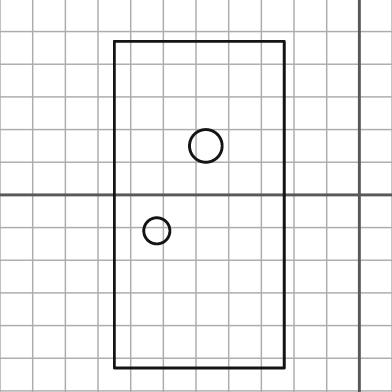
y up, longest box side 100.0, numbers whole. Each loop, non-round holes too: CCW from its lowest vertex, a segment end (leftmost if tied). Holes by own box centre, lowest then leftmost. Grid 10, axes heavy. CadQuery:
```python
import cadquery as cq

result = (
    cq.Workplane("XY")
    .moveTo(-75.0, -53.0)
    .lineTo(-23.0, -53.0)
    .lineTo(-23.0, 47.0)
    .lineTo(-75.0, 47.0)
    .close()
    .moveTo(-62.0, -11.0)
    .circle(4.0)
    .moveTo(-47.0, 15.0)
    .circle(5.0)
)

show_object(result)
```